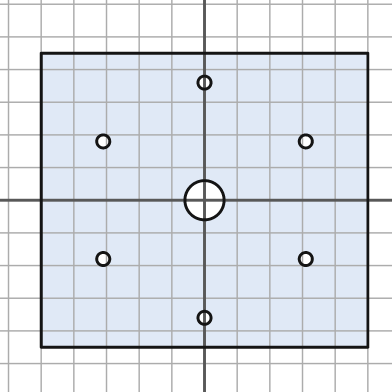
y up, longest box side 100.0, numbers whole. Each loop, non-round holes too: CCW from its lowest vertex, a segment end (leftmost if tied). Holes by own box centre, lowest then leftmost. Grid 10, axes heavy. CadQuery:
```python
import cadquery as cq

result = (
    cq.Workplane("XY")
    .moveTo(-50.0, -45.0)
    .lineTo(50.0, -45.0)
    .lineTo(50.0, 45.0)
    .lineTo(-50.0, 45.0)
    .close()
    .moveTo(0.0, -36.0)
    .circle(2.0)
    .moveTo(-31.0, -18.0)
    .circle(2.0)
    .moveTo(31.0, -18.0)
    .circle(2.0)
    .moveTo(0.0, 0.0)
    .circle(6.0)
    .moveTo(-31.0, 18.0)
    .circle(2.0)
    .moveTo(31.0, 18.0)
    .circle(2.0)
    .moveTo(0.0, 36.0)
    .circle(2.0)
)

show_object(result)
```